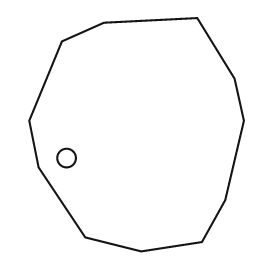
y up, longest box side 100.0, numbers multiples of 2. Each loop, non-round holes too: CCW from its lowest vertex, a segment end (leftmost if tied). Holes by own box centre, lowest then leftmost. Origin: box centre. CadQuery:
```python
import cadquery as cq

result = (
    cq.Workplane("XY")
    .moveTo(2.0, -50.0)
    .lineTo(28.0, -46.0)
    .lineTo(38.0, -28.0)
    .lineTo(46.0, 6.0)
    .lineTo(42.0, 24.0)
    .lineTo(26.0, 50.0)
    .lineTo(-14.0, 48.0)
    .lineTo(-32.0, 40.0)
    .lineTo(-46.0, 6.0)
    .lineTo(-42.0, -14.0)
    .lineTo(-22.0, -44.0)
    .close()
    .moveTo(-30.0, -10.0)
    .circle(4.0)
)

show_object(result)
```